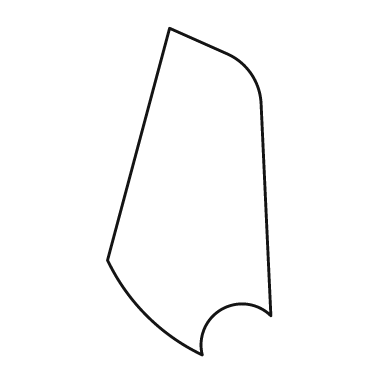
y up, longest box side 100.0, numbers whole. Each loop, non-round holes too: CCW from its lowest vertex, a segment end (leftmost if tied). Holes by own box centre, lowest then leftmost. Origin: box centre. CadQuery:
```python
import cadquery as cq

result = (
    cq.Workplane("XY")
    .moveTo(4.0, -50.0)
    .threePointArc((10.0, -36.0), (25.0, -38.0))
    .lineTo(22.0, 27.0)
    .threePointArc((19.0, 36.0), (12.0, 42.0))
    .lineTo(-6.0, 50.0)
    .lineTo(-25.0, -21.0)
    .threePointArc((-13.0, -38.0), (4.0, -50.0))
    .close()
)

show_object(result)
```